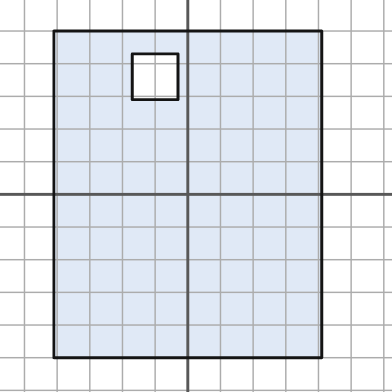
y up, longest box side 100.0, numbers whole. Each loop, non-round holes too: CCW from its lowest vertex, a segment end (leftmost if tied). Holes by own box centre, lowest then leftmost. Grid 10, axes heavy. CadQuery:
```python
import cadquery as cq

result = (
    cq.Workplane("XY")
    .moveTo(-41.0, -50.0)
    .lineTo(41.0, -50.0)
    .lineTo(41.0, 50.0)
    .lineTo(-41.0, 50.0)
    .close()
    .moveTo(-17.0, 29.0)
    .lineTo(-3.0, 29.0)
    .lineTo(-3.0, 43.0)
    .lineTo(-17.0, 43.0)
    .close()
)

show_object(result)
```